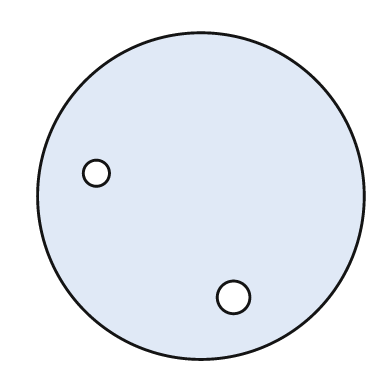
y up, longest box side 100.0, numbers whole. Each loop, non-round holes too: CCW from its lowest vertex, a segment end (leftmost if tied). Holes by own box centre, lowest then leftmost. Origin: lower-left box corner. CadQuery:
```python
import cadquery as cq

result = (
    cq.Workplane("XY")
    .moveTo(50.0, 50.0)
    .circle(50.0)
    .moveTo(60.0, 19.0)
    .circle(5.0)
    .moveTo(18.0, 57.0)
    .circle(4.0)
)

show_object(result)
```